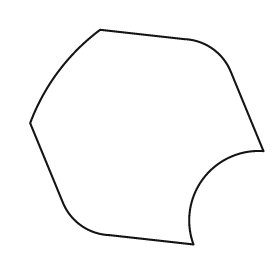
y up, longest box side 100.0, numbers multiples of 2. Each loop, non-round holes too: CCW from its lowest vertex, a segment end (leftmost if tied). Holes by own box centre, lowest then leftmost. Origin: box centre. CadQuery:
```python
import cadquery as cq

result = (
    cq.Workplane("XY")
    .moveTo(20.0, -46.0)
    .threePointArc((24.0, -18.0), (50.0, -6.0))
    .lineTo(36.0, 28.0)
    .threePointArc((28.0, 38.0), (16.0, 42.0))
    .lineTo(-20.0, 46.0)
    .threePointArc((-38.0, 28.0), (-50.0, 6.0))
    .lineTo(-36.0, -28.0)
    .threePointArc((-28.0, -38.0), (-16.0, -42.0))
    .close()
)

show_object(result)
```